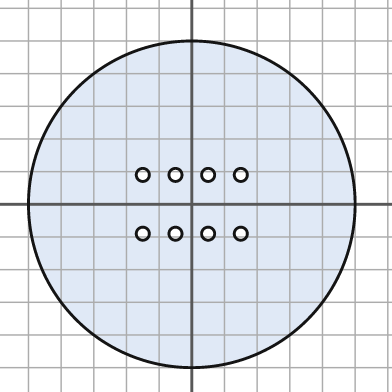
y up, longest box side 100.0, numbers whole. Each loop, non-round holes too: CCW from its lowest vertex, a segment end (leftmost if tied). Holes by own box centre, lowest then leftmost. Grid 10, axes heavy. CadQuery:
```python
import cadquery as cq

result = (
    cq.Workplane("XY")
    .moveTo(0.0, 0.0)
    .circle(50.0)
    .moveTo(-15.0, -9.0)
    .circle(2.0)
    .moveTo(-5.0, -9.0)
    .circle(2.0)
    .moveTo(5.0, -9.0)
    .circle(2.0)
    .moveTo(15.0, -9.0)
    .circle(2.0)
    .moveTo(-15.0, 9.0)
    .circle(2.0)
    .moveTo(-5.0, 9.0)
    .circle(2.0)
    .moveTo(5.0, 9.0)
    .circle(2.0)
    .moveTo(15.0, 9.0)
    .circle(2.0)
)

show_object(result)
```